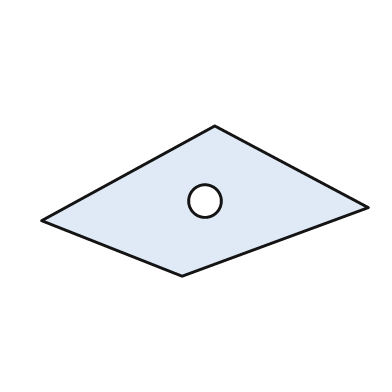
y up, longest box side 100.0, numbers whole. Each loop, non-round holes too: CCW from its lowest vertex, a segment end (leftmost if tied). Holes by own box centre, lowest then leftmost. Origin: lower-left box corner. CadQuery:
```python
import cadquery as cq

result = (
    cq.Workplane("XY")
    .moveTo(43.0, 0.0)
    .lineTo(100.0, 21.0)
    .lineTo(53.0, 46.0)
    .lineTo(0.0, 17.0)
    .close()
    .moveTo(50.0, 23.0)
    .circle(5.0)
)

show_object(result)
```